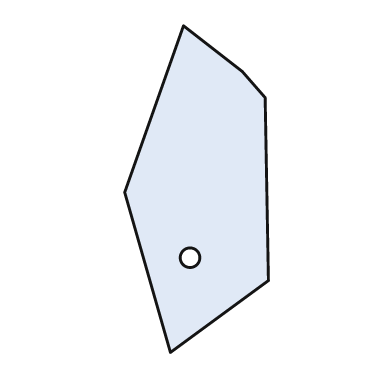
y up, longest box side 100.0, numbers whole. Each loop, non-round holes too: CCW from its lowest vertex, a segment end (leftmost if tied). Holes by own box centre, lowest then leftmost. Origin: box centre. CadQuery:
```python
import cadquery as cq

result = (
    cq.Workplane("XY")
    .moveTo(-8.0, -50.0)
    .lineTo(22.0, -28.0)
    .lineTo(21.0, 28.0)
    .lineTo(14.0, 36.0)
    .lineTo(-4.0, 50.0)
    .lineTo(-22.0, -1.0)
    .close()
    .moveTo(-2.0, -21.0)
    .circle(3.0)
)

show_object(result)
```